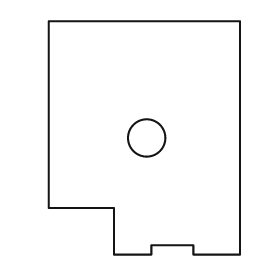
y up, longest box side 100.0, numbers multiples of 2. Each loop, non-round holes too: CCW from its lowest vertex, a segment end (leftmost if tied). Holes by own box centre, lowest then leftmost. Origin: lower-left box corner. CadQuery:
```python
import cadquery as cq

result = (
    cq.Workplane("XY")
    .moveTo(28.0, 0.0)
    .lineTo(44.0, 0.0)
    .lineTo(44.0, 4.0)
    .lineTo(62.0, 4.0)
    .lineTo(62.0, 0.0)
    .lineTo(82.0, 0.0)
    .lineTo(82.0, 100.0)
    .lineTo(0.0, 100.0)
    .lineTo(0.0, 20.0)
    .lineTo(28.0, 20.0)
    .close()
    .moveTo(42.0, 50.0)
    .circle(8.0)
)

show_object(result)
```